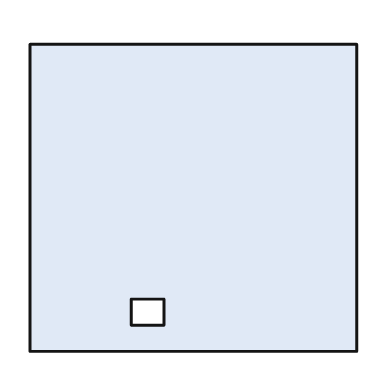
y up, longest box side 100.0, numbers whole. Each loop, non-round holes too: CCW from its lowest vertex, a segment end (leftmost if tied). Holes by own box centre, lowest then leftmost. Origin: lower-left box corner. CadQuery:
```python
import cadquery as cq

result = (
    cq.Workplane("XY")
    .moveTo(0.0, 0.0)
    .lineTo(100.0, 0.0)
    .lineTo(100.0, 94.0)
    .lineTo(0.0, 94.0)
    .close()
    .moveTo(31.0, 8.0)
    .lineTo(41.0, 8.0)
    .lineTo(41.0, 16.0)
    .lineTo(31.0, 16.0)
    .close()
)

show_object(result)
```